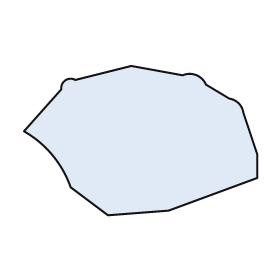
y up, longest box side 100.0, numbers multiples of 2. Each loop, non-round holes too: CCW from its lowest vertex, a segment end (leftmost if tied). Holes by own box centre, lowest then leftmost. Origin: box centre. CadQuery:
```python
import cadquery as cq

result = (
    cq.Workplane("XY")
    .moveTo(-14.0, -32.0)
    .lineTo(12.0, -30.0)
    .lineTo(50.0, -16.0)
    .lineTo(50.0, -6.0)
    .lineTo(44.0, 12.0)
    .threePointArc((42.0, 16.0), (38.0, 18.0))
    .lineTo(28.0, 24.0)
    .threePointArc((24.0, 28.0), (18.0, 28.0))
    .lineTo(-4.0, 32.0)
    .lineTo(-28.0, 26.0)
    .threePointArc((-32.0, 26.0), (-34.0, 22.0))
    .lineTo(-50.0, 4.0)
    .threePointArc((-38.0, -6.0), (-30.0, -20.0))
    .close()
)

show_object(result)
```